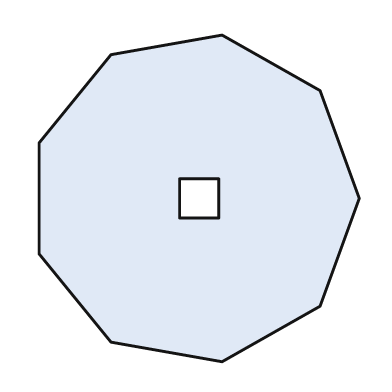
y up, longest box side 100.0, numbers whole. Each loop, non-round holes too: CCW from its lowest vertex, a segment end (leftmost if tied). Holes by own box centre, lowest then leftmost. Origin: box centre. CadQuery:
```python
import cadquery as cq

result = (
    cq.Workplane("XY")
    .moveTo(7.0, -50.0)
    .lineTo(37.0, -33.0)
    .lineTo(49.0, 0.0)
    .lineTo(37.0, 33.0)
    .lineTo(7.0, 50.0)
    .lineTo(-27.0, 44.0)
    .lineTo(-49.0, 17.0)
    .lineTo(-49.0, -17.0)
    .lineTo(-27.0, -44.0)
    .close()
    .moveTo(-6.0, -6.0)
    .lineTo(6.0, -6.0)
    .lineTo(6.0, 6.0)
    .lineTo(-6.0, 6.0)
    .close()
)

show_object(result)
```